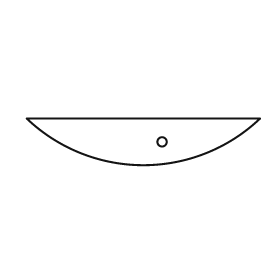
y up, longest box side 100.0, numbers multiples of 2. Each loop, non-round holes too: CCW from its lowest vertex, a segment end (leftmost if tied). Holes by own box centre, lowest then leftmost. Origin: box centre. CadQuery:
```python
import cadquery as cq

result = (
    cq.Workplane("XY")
    .moveTo(-50.0, 10.0)
    .threePointArc((0.0, -10.0), (50.0, 10.0))
    .close()
    .moveTo(8.0, 0.0)
    .circle(2.0)
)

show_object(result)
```